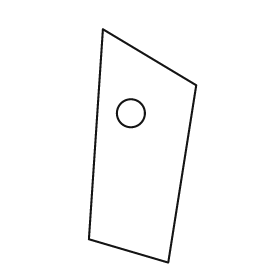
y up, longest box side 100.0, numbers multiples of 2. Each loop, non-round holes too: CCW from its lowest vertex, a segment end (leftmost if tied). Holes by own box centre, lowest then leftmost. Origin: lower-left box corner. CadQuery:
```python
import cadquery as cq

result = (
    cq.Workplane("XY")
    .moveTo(34.0, 0.0)
    .lineTo(46.0, 76.0)
    .lineTo(6.0, 100.0)
    .lineTo(0.0, 10.0)
    .close()
    .moveTo(18.0, 64.0)
    .circle(6.0)
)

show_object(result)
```